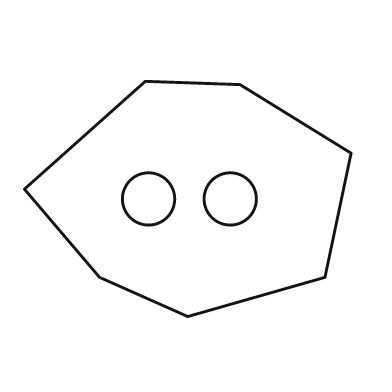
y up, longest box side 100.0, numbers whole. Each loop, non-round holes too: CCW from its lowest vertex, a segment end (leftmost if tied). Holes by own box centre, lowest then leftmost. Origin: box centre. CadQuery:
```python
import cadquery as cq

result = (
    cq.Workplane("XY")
    .moveTo(0.0, -36.0)
    .lineTo(42.0, -24.0)
    .lineTo(50.0, 14.0)
    .lineTo(16.0, 35.0)
    .lineTo(-13.0, 36.0)
    .lineTo(-50.0, 3.0)
    .lineTo(-27.0, -24.0)
    .close()
    .moveTo(-12.0, 0.0)
    .circle(8.0)
    .moveTo(13.0, 0.0)
    .circle(8.0)
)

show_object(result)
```